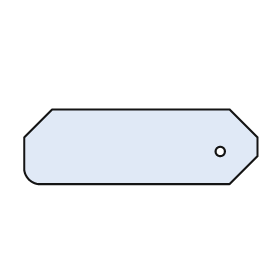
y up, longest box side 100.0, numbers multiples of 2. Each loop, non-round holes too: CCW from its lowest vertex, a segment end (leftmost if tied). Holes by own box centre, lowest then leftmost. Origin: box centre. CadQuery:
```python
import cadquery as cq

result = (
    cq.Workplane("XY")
    .moveTo(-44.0, -16.0)
    .lineTo(38.0, -16.0)
    .lineTo(50.0, -4.0)
    .lineTo(50.0, 4.0)
    .lineTo(38.0, 16.0)
    .lineTo(-38.0, 16.0)
    .lineTo(-50.0, 4.0)
    .lineTo(-50.0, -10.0)
    .threePointArc((-48.0, -14.0), (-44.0, -16.0))
    .close()
    .moveTo(34.0, -2.0)
    .circle(2.0)
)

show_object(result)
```